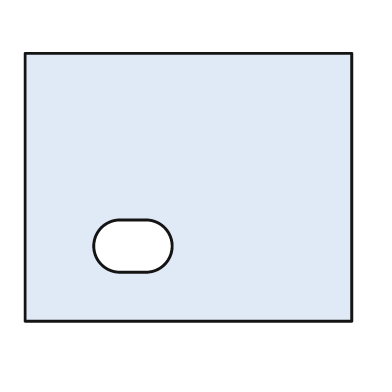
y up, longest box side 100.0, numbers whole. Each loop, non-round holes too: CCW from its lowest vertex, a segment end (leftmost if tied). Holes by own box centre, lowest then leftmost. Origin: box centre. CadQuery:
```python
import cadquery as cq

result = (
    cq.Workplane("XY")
    .moveTo(-50.0, -41.0)
    .lineTo(50.0, -41.0)
    .lineTo(50.0, 41.0)
    .lineTo(-50.0, 41.0)
    .close()
    .moveTo(-21.0, -26.0)
    .lineTo(-13.0, -26.0)
    .threePointArc((-5.0, -18.0), (-13.0, -10.0))
    .lineTo(-21.0, -10.0)
    .threePointArc((-29.0, -18.0), (-21.0, -26.0))
    .close()
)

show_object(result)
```